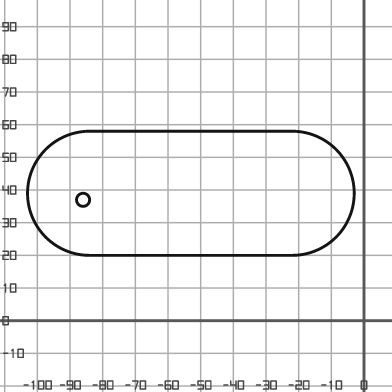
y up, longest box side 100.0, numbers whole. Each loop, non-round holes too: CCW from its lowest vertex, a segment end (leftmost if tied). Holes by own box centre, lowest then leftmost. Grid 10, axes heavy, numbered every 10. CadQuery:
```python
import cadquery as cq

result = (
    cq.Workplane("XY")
    .moveTo(-84.0, 20.0)
    .lineTo(-22.0, 20.0)
    .threePointArc((-3.0, 39.0), (-22.0, 58.0))
    .lineTo(-84.0, 58.0)
    .threePointArc((-103.0, 39.0), (-84.0, 20.0))
    .close()
    .moveTo(-86.0, 37.0)
    .circle(2.0)
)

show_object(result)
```